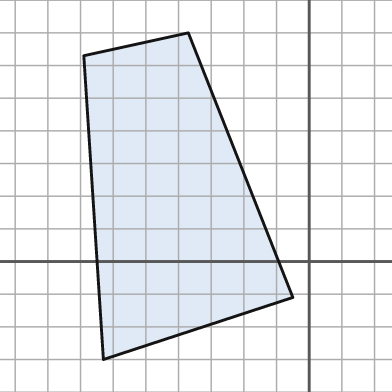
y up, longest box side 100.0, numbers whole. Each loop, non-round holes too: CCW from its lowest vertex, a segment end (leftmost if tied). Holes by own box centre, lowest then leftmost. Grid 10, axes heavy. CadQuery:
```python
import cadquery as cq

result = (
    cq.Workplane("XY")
    .moveTo(-63.0, -30.0)
    .lineTo(-5.0, -11.0)
    .lineTo(-37.0, 70.0)
    .lineTo(-69.0, 63.0)
    .close()
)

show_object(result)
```